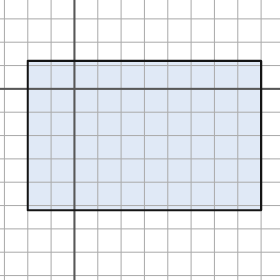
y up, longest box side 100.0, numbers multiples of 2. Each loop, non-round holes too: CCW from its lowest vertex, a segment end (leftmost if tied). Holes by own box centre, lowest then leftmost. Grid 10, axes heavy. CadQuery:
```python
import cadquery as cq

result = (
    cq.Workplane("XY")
    .moveTo(-20.0, -52.0)
    .lineTo(80.0, -52.0)
    .lineTo(80.0, 12.0)
    .lineTo(-20.0, 12.0)
    .close()
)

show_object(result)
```